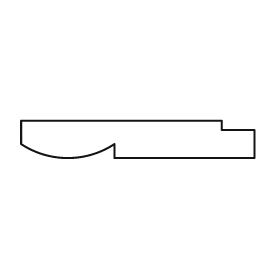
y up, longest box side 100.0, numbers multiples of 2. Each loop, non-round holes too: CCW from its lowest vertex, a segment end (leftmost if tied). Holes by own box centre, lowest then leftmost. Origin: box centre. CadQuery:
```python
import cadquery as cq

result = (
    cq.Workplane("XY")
    .moveTo(-10.0, -8.0)
    .lineTo(50.0, -8.0)
    .lineTo(50.0, 4.0)
    .lineTo(36.0, 4.0)
    .lineTo(36.0, 8.0)
    .lineTo(-50.0, 8.0)
    .lineTo(-50.0, -2.0)
    .threePointArc((-30.0, -8.0), (-10.0, -2.0))
    .close()
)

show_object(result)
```